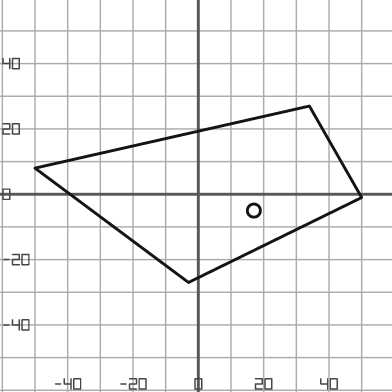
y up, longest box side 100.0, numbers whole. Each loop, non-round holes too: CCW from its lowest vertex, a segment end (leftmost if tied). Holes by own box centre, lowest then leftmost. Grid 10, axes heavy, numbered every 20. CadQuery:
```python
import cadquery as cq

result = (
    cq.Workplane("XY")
    .moveTo(-3.0, -27.0)
    .lineTo(50.0, -1.0)
    .lineTo(34.0, 27.0)
    .lineTo(-50.0, 8.0)
    .close()
    .moveTo(17.0, -5.0)
    .circle(2.0)
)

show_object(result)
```